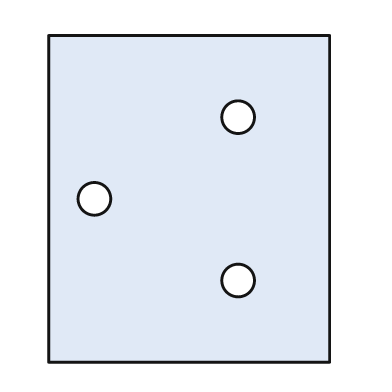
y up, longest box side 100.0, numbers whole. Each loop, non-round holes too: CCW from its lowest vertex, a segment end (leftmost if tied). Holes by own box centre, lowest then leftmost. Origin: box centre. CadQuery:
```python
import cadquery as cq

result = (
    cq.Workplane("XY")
    .moveTo(-43.0, -50.0)
    .lineTo(43.0, -50.0)
    .lineTo(43.0, 50.0)
    .lineTo(-43.0, 50.0)
    .close()
    .moveTo(15.0, -25.0)
    .circle(5.0)
    .moveTo(-29.0, 0.0)
    .circle(5.0)
    .moveTo(15.0, 25.0)
    .circle(5.0)
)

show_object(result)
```